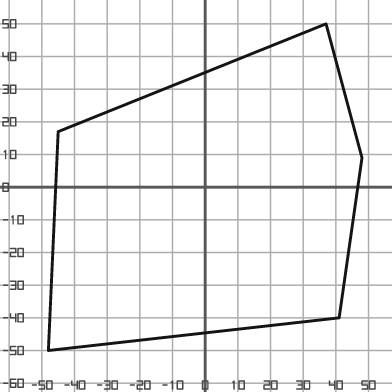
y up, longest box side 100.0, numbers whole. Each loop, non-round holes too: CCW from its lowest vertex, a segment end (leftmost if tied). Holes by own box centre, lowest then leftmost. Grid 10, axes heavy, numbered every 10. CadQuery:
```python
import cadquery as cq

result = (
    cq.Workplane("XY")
    .moveTo(-48.0, -50.0)
    .lineTo(41.0, -40.0)
    .lineTo(48.0, 9.0)
    .lineTo(37.0, 50.0)
    .lineTo(-45.0, 17.0)
    .close()
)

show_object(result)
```